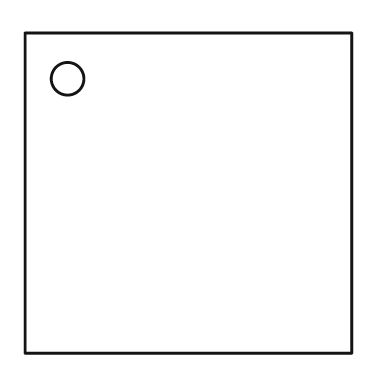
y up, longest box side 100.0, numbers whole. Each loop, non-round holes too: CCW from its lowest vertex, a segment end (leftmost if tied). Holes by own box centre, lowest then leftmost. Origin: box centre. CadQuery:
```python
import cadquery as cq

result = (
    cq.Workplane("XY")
    .moveTo(-50.0, -49.0)
    .lineTo(50.0, -49.0)
    .lineTo(50.0, 49.0)
    .lineTo(-50.0, 49.0)
    .close()
    .moveTo(-37.0, 35.0)
    .circle(5.0)
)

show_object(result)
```